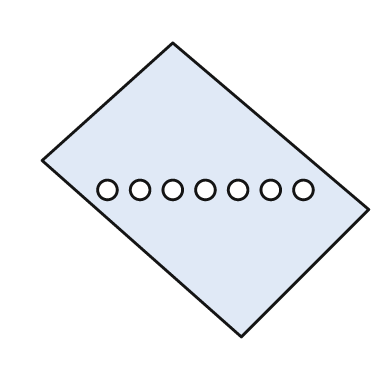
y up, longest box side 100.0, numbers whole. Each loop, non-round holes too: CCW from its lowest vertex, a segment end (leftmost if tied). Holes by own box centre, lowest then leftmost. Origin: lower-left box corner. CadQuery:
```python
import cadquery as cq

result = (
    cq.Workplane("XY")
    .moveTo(61.0, 0.0)
    .lineTo(100.0, 39.0)
    .lineTo(40.0, 90.0)
    .lineTo(0.0, 54.0)
    .close()
    .moveTo(20.0, 45.0)
    .circle(3.0)
    .moveTo(30.0, 45.0)
    .circle(3.0)
    .moveTo(40.0, 45.0)
    .circle(3.0)
    .moveTo(50.0, 45.0)
    .circle(3.0)
    .moveTo(60.0, 45.0)
    .circle(3.0)
    .moveTo(70.0, 45.0)
    .circle(3.0)
    .moveTo(80.0, 45.0)
    .circle(3.0)
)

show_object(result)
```